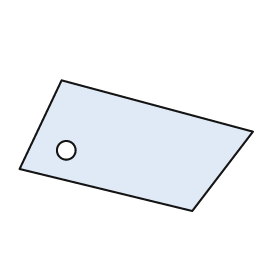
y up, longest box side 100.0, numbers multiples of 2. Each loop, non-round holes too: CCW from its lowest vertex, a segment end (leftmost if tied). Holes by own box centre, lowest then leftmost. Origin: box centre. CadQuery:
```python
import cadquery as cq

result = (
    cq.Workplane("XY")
    .moveTo(24.0, -28.0)
    .lineTo(50.0, 6.0)
    .lineTo(-32.0, 28.0)
    .lineTo(-50.0, -10.0)
    .close()
    .moveTo(-30.0, -2.0)
    .circle(4.0)
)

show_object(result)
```